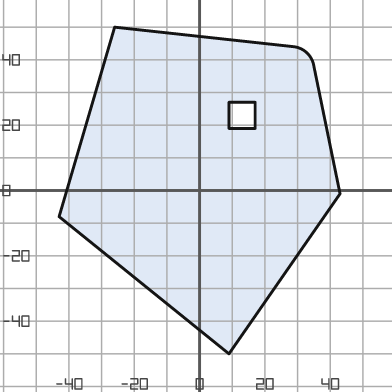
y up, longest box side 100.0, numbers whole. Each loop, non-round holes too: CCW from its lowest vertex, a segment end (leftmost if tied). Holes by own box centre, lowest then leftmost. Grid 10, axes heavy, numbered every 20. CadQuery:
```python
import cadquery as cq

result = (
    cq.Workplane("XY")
    .moveTo(9.0, -50.0)
    .lineTo(43.0, -1.0)
    .lineTo(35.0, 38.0)
    .threePointArc((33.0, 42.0), (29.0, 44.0))
    .lineTo(-26.0, 50.0)
    .lineTo(-43.0, -8.0)
    .close()
    .moveTo(9.0, 19.0)
    .lineTo(17.0, 19.0)
    .lineTo(17.0, 27.0)
    .lineTo(9.0, 27.0)
    .close()
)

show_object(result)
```